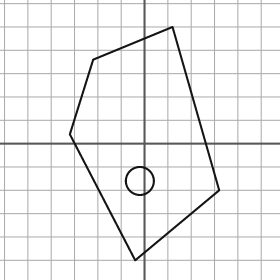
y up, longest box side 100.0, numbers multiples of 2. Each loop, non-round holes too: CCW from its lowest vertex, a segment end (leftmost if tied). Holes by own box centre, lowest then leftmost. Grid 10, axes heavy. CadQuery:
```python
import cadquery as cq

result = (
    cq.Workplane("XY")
    .moveTo(-4.0, -50.0)
    .lineTo(32.0, -20.0)
    .lineTo(12.0, 50.0)
    .lineTo(-22.0, 36.0)
    .lineTo(-32.0, 4.0)
    .close()
    .moveTo(-2.0, -16.0)
    .circle(6.0)
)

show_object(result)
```